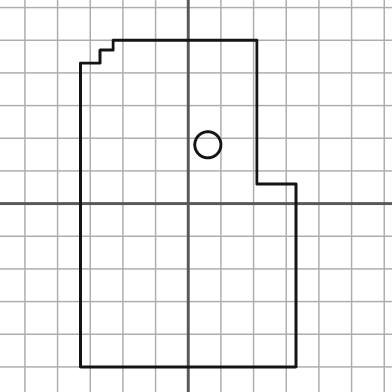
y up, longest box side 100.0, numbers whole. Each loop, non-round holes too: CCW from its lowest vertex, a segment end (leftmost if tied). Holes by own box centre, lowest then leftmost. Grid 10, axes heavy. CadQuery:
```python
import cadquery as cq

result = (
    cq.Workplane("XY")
    .moveTo(-33.0, -50.0)
    .lineTo(33.0, -50.0)
    .lineTo(33.0, 6.0)
    .lineTo(21.0, 6.0)
    .lineTo(21.0, 50.0)
    .lineTo(-23.0, 50.0)
    .lineTo(-23.0, 47.0)
    .lineTo(-27.0, 47.0)
    .lineTo(-27.0, 43.0)
    .lineTo(-33.0, 43.0)
    .close()
    .moveTo(6.0, 18.0)
    .circle(4.0)
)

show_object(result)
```